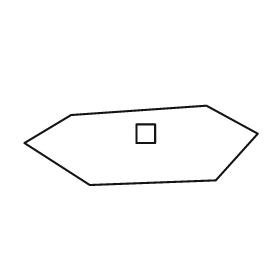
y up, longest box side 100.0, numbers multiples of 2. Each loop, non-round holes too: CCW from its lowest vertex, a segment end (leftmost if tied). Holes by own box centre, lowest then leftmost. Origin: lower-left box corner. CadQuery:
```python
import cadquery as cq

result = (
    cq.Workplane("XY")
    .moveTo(28.0, 0.0)
    .lineTo(82.0, 2.0)
    .lineTo(100.0, 22.0)
    .lineTo(78.0, 34.0)
    .lineTo(20.0, 30.0)
    .lineTo(0.0, 18.0)
    .close()
    .moveTo(48.0, 18.0)
    .lineTo(56.0, 18.0)
    .lineTo(56.0, 26.0)
    .lineTo(48.0, 26.0)
    .close()
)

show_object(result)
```